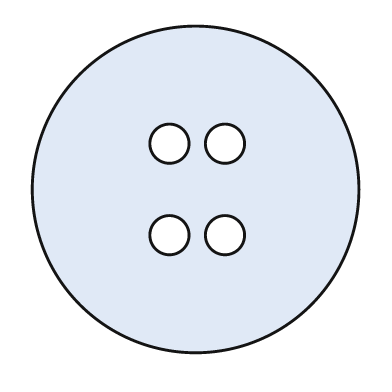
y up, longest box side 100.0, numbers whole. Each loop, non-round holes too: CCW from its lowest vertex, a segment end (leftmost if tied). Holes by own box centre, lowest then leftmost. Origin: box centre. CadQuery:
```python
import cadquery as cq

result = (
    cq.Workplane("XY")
    .moveTo(0.0, 0.0)
    .circle(50.0)
    .moveTo(-8.0, -14.0)
    .circle(6.0)
    .moveTo(9.0, -14.0)
    .circle(6.0)
    .moveTo(-8.0, 14.0)
    .circle(6.0)
    .moveTo(9.0, 14.0)
    .circle(6.0)
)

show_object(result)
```